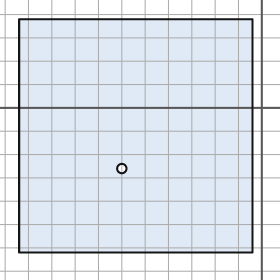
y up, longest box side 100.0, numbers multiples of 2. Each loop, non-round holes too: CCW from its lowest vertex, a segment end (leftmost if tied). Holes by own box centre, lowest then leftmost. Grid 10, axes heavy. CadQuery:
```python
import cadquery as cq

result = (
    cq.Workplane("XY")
    .moveTo(-104.0, -62.0)
    .lineTo(-4.0, -62.0)
    .lineTo(-4.0, 38.0)
    .lineTo(-104.0, 38.0)
    .close()
    .moveTo(-60.0, -26.0)
    .circle(2.0)
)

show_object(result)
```